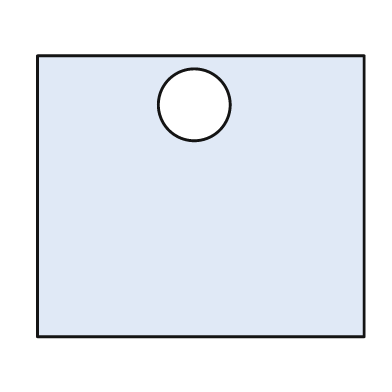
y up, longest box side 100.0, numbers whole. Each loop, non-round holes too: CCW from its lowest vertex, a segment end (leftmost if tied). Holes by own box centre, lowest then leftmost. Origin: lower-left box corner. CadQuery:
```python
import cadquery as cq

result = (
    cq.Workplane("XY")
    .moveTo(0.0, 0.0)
    .lineTo(100.0, 0.0)
    .lineTo(100.0, 86.0)
    .lineTo(0.0, 86.0)
    .close()
    .moveTo(48.0, 71.0)
    .circle(11.0)
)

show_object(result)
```